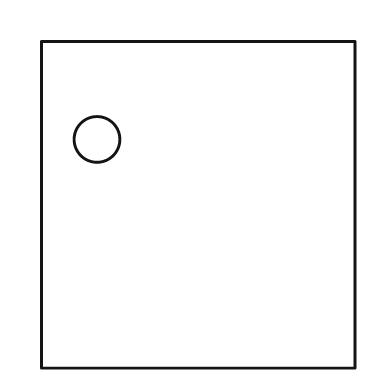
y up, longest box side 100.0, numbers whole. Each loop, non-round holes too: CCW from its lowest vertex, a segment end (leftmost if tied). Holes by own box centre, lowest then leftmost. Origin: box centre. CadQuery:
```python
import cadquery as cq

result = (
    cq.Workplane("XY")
    .moveTo(-48.0, -50.0)
    .lineTo(48.0, -50.0)
    .lineTo(48.0, 50.0)
    .lineTo(-48.0, 50.0)
    .close()
    .moveTo(-31.0, 20.0)
    .circle(7.0)
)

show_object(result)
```